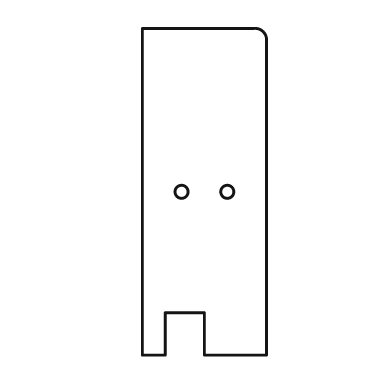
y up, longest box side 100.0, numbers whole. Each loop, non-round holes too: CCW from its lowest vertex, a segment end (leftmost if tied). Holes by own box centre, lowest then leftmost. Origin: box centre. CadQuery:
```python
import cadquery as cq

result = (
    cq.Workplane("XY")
    .moveTo(-19.0, -50.0)
    .lineTo(-12.0, -50.0)
    .lineTo(-12.0, -37.0)
    .lineTo(0.0, -37.0)
    .lineTo(0.0, -50.0)
    .lineTo(19.0, -50.0)
    .lineTo(19.0, 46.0)
    .threePointArc((18.0, 49.0), (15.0, 50.0))
    .lineTo(-19.0, 50.0)
    .close()
    .moveTo(-7.0, 0.0)
    .circle(2.0)
    .moveTo(7.0, 0.0)
    .circle(2.0)
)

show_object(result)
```